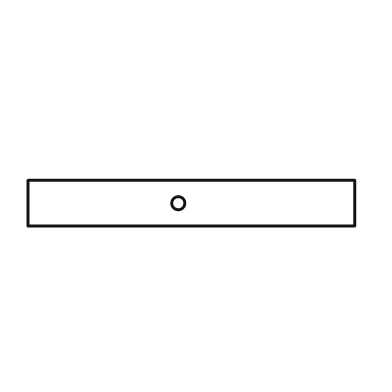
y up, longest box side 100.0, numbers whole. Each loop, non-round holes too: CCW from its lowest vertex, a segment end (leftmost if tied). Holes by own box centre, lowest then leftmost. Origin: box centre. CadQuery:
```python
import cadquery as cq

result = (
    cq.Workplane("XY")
    .moveTo(-50.0, -7.0)
    .lineTo(50.0, -7.0)
    .lineTo(50.0, 7.0)
    .lineTo(-50.0, 7.0)
    .close()
    .moveTo(-4.0, 0.0)
    .circle(2.0)
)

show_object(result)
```